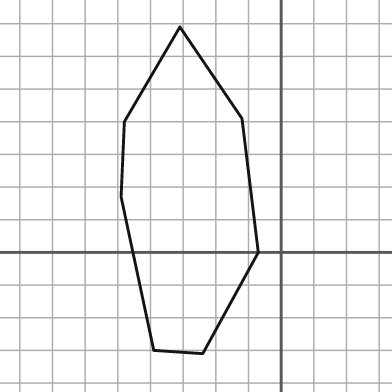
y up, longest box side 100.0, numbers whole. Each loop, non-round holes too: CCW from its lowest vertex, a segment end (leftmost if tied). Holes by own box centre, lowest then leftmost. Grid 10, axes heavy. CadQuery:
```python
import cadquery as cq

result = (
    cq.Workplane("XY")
    .moveTo(-24.0, -31.0)
    .lineTo(-7.0, 0.0)
    .lineTo(-12.0, 41.0)
    .lineTo(-31.0, 69.0)
    .lineTo(-48.0, 40.0)
    .lineTo(-49.0, 17.0)
    .lineTo(-39.0, -30.0)
    .close()
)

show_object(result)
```